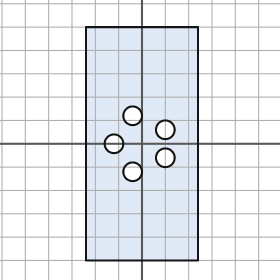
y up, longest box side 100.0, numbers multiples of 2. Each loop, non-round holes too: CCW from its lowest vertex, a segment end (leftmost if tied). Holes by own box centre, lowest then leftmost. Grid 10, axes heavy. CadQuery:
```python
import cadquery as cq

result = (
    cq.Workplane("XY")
    .moveTo(-24.0, -50.0)
    .lineTo(24.0, -50.0)
    .lineTo(24.0, 50.0)
    .lineTo(-24.0, 50.0)
    .close()
    .moveTo(-4.0, -12.0)
    .circle(4.0)
    .moveTo(10.0, -6.0)
    .circle(4.0)
    .moveTo(-12.0, 0.0)
    .circle(4.0)
    .moveTo(10.0, 6.0)
    .circle(4.0)
    .moveTo(-4.0, 12.0)
    .circle(4.0)
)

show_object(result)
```